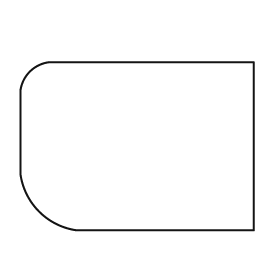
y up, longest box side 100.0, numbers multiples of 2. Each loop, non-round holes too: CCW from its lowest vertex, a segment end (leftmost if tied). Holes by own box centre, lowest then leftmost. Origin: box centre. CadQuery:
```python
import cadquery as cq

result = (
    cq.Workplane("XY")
    .moveTo(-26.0, -36.0)
    .lineTo(50.0, -36.0)
    .lineTo(50.0, 36.0)
    .lineTo(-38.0, 36.0)
    .threePointArc((-46.0, 32.0), (-50.0, 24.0))
    .lineTo(-50.0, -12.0)
    .threePointArc((-42.0, -28.0), (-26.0, -36.0))
    .close()
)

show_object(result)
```